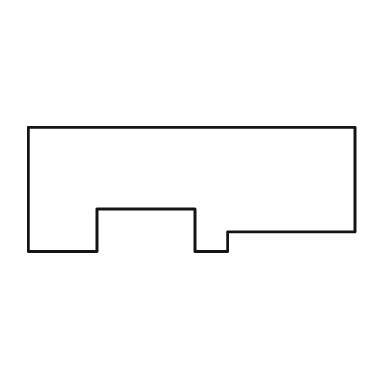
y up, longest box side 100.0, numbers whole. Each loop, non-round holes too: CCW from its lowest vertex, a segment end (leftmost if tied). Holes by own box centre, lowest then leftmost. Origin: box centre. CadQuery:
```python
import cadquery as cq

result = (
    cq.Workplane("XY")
    .moveTo(-50.0, -19.0)
    .lineTo(-29.0, -19.0)
    .lineTo(-29.0, -6.0)
    .lineTo(1.0, -6.0)
    .lineTo(1.0, -19.0)
    .lineTo(11.0, -19.0)
    .lineTo(11.0, -13.0)
    .lineTo(50.0, -13.0)
    .lineTo(50.0, 19.0)
    .lineTo(-50.0, 19.0)
    .close()
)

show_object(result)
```